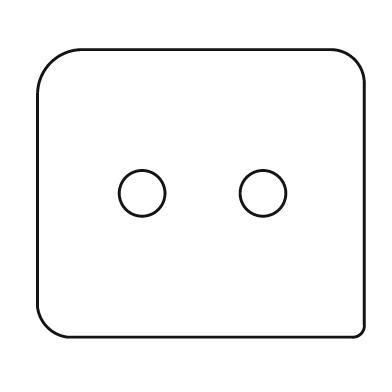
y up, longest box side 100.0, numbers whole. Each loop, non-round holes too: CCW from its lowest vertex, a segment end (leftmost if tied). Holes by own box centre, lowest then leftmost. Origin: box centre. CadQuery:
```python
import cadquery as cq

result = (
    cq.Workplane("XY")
    .moveTo(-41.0, -44.0)
    .lineTo(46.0, -44.0)
    .threePointArc((49.0, -43.0), (50.0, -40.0))
    .lineTo(50.0, 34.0)
    .threePointArc((47.0, 41.0), (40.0, 44.0))
    .lineTo(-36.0, 44.0)
    .threePointArc((-46.0, 40.0), (-50.0, 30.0))
    .lineTo(-50.0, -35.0)
    .threePointArc((-47.0, -41.0), (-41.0, -44.0))
    .close()
    .moveTo(-18.0, 0.0)
    .circle(7.0)
    .moveTo(19.0, 0.0)
    .circle(7.0)
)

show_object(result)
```